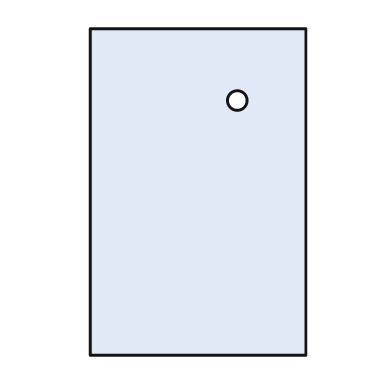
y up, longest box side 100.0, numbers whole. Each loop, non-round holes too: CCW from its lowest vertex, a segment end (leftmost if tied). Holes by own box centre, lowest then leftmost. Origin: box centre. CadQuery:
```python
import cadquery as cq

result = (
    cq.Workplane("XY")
    .moveTo(-33.0, -50.0)
    .lineTo(33.0, -50.0)
    .lineTo(33.0, 50.0)
    .lineTo(-33.0, 50.0)
    .close()
    .moveTo(12.0, 28.0)
    .circle(3.0)
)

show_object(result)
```